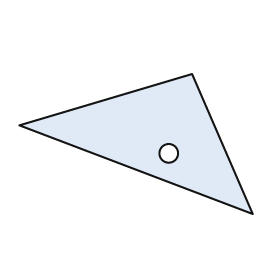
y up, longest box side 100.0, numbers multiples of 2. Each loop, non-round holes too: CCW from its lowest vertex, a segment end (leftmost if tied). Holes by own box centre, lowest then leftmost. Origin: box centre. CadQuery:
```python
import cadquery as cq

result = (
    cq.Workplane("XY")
    .moveTo(50.0, -30.0)
    .lineTo(24.0, 30.0)
    .lineTo(-50.0, 8.0)
    .close()
    .moveTo(14.0, -4.0)
    .circle(4.0)
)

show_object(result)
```